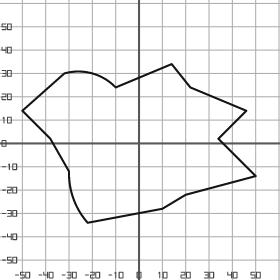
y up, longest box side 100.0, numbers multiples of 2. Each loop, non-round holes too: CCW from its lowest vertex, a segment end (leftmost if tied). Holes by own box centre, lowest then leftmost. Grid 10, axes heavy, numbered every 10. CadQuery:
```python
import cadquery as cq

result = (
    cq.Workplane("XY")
    .moveTo(-22.0, -34.0)
    .lineTo(10.0, -28.0)
    .lineTo(20.0, -22.0)
    .lineTo(50.0, -14.0)
    .lineTo(34.0, 2.0)
    .lineTo(46.0, 14.0)
    .lineTo(22.0, 24.0)
    .lineTo(14.0, 34.0)
    .lineTo(-10.0, 24.0)
    .threePointArc((-20.0, 30.0), (-32.0, 30.0))
    .lineTo(-50.0, 14.0)
    .lineTo(-38.0, 2.0)
    .lineTo(-30.0, -12.0)
    .threePointArc((-28.0, -24.0), (-22.0, -34.0))
    .close()
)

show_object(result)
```